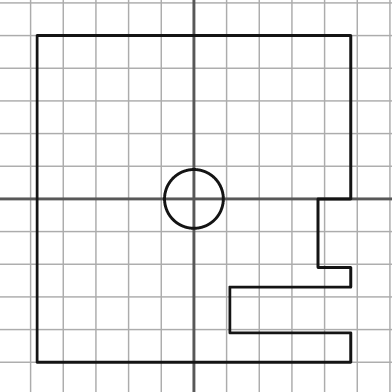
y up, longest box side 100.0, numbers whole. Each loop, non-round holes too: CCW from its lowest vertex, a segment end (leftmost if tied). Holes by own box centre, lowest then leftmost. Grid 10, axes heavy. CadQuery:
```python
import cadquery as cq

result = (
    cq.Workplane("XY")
    .moveTo(-48.0, -50.0)
    .lineTo(48.0, -50.0)
    .lineTo(48.0, -41.0)
    .lineTo(11.0, -41.0)
    .lineTo(11.0, -27.0)
    .lineTo(48.0, -27.0)
    .lineTo(48.0, -21.0)
    .lineTo(38.0, -21.0)
    .lineTo(38.0, 0.0)
    .lineTo(48.0, 0.0)
    .lineTo(48.0, 50.0)
    .lineTo(-48.0, 50.0)
    .close()
    .moveTo(0.0, 0.0)
    .circle(9.0)
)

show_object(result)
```